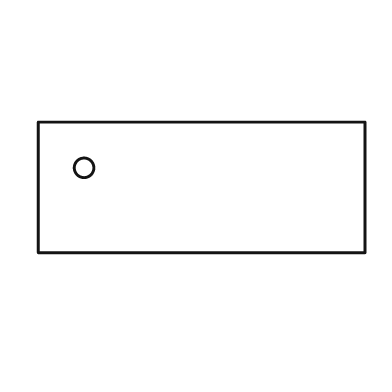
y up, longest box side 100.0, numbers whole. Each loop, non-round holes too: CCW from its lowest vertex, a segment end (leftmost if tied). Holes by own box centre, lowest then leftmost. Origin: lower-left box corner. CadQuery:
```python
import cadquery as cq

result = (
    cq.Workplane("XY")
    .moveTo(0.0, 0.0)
    .lineTo(100.0, 0.0)
    .lineTo(100.0, 40.0)
    .lineTo(0.0, 40.0)
    .close()
    .moveTo(14.0, 26.0)
    .circle(3.0)
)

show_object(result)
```